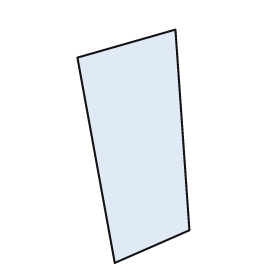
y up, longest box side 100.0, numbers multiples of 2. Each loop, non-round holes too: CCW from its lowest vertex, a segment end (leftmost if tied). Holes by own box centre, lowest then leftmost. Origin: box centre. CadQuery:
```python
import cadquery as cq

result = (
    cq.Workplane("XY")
    .moveTo(-8.0, -50.0)
    .lineTo(24.0, -36.0)
    .lineTo(18.0, 50.0)
    .lineTo(-24.0, 38.0)
    .close()
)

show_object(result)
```